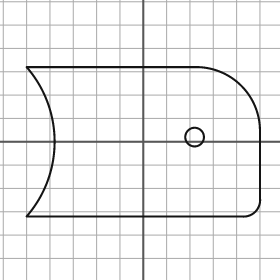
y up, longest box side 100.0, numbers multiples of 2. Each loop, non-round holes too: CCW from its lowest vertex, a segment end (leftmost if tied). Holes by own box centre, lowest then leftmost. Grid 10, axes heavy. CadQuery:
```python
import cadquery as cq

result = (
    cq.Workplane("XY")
    .moveTo(-50.0, -32.0)
    .lineTo(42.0, -32.0)
    .threePointArc((48.0, -30.0), (50.0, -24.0))
    .lineTo(50.0, 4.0)
    .threePointArc((42.0, 24.0), (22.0, 32.0))
    .lineTo(-50.0, 32.0)
    .threePointArc((-38.0, 0.0), (-50.0, -32.0))
    .close()
    .moveTo(22.0, 2.0)
    .circle(4.0)
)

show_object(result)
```